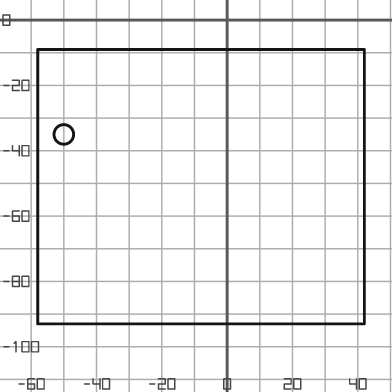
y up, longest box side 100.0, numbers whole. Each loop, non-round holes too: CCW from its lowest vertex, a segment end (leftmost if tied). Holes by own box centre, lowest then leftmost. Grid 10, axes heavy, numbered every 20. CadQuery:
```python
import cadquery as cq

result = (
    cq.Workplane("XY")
    .moveTo(-58.0, -93.0)
    .lineTo(42.0, -93.0)
    .lineTo(42.0, -9.0)
    .lineTo(-58.0, -9.0)
    .close()
    .moveTo(-50.0, -35.0)
    .circle(3.0)
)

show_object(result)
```